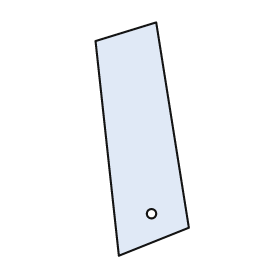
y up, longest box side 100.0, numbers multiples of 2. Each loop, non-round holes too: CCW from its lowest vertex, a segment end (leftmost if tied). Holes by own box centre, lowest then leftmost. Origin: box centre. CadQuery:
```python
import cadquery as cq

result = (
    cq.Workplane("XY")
    .moveTo(-10.0, -50.0)
    .lineTo(20.0, -38.0)
    .lineTo(6.0, 50.0)
    .lineTo(-20.0, 42.0)
    .close()
    .moveTo(4.0, -32.0)
    .circle(2.0)
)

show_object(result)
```